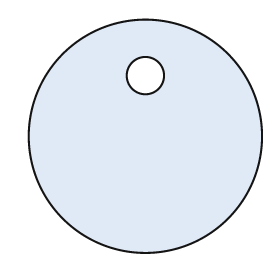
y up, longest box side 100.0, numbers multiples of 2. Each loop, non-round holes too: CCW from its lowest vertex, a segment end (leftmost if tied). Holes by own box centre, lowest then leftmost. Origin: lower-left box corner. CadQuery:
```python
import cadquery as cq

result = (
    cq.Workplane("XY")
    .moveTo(50.0, 50.0)
    .circle(50.0)
    .moveTo(50.0, 76.0)
    .circle(8.0)
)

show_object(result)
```